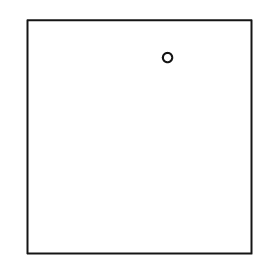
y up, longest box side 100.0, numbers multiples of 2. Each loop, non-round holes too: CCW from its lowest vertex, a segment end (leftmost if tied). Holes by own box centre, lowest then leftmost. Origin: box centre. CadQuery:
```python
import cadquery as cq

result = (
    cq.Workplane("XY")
    .moveTo(-48.0, -50.0)
    .lineTo(48.0, -50.0)
    .lineTo(48.0, 50.0)
    .lineTo(-48.0, 50.0)
    .close()
    .moveTo(12.0, 34.0)
    .circle(2.0)
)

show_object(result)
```